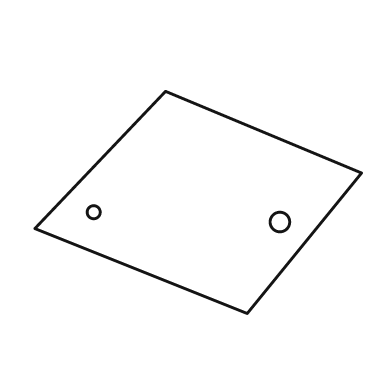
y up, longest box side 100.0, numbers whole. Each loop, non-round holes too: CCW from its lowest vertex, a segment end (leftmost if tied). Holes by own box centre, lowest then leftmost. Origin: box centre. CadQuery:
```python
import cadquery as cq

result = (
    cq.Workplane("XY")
    .moveTo(15.0, -34.0)
    .lineTo(50.0, 9.0)
    .lineTo(-10.0, 34.0)
    .lineTo(-50.0, -8.0)
    .close()
    .moveTo(25.0, -6.0)
    .circle(3.0)
    .moveTo(-32.0, -3.0)
    .circle(2.0)
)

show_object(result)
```